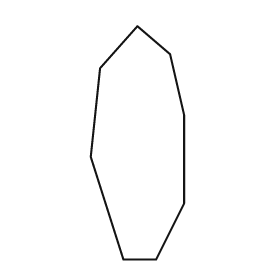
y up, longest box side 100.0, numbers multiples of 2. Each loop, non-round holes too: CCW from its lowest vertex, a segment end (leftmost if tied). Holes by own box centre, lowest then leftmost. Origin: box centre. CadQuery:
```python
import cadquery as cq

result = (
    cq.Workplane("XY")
    .moveTo(-6.0, -50.0)
    .lineTo(8.0, -50.0)
    .lineTo(20.0, -26.0)
    .lineTo(20.0, 12.0)
    .lineTo(14.0, 38.0)
    .lineTo(0.0, 50.0)
    .lineTo(-16.0, 32.0)
    .lineTo(-20.0, -6.0)
    .close()
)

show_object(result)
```